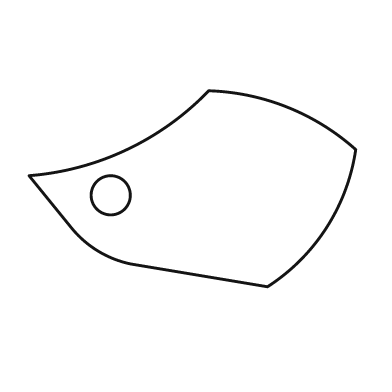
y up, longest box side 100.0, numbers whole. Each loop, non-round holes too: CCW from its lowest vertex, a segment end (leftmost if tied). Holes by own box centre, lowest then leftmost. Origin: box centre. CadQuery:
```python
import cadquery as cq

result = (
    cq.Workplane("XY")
    .moveTo(23.0, -30.0)
    .threePointArc((41.0, -12.0), (50.0, 12.0))
    .threePointArc((29.0, 25.0), (5.0, 30.0))
    .threePointArc((-20.0, 12.0), (-50.0, 4.0))
    .lineTo(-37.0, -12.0)
    .threePointArc((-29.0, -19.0), (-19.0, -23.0))
    .close()
    .moveTo(-25.0, -2.0)
    .circle(6.0)
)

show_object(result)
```